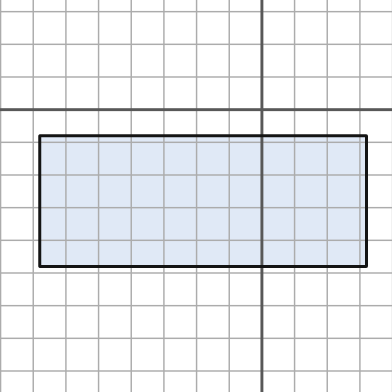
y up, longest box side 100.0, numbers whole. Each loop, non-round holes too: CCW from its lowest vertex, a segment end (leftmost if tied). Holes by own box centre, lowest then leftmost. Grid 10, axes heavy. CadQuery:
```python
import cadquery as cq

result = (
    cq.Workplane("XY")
    .moveTo(-68.0, -48.0)
    .lineTo(32.0, -48.0)
    .lineTo(32.0, -8.0)
    .lineTo(-68.0, -8.0)
    .close()
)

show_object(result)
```